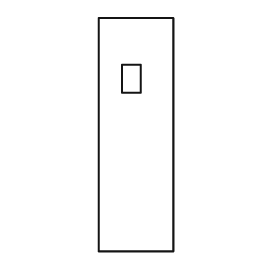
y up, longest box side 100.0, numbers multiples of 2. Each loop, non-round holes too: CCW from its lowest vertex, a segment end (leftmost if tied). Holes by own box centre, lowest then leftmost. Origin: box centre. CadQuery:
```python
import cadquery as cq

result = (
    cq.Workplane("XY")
    .moveTo(-16.0, -50.0)
    .lineTo(16.0, -50.0)
    .lineTo(16.0, 50.0)
    .lineTo(-16.0, 50.0)
    .close()
    .moveTo(-6.0, 18.0)
    .lineTo(2.0, 18.0)
    .lineTo(2.0, 30.0)
    .lineTo(-6.0, 30.0)
    .close()
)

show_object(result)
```